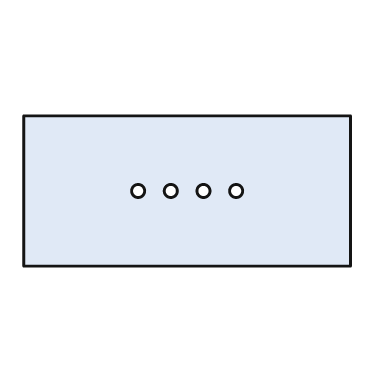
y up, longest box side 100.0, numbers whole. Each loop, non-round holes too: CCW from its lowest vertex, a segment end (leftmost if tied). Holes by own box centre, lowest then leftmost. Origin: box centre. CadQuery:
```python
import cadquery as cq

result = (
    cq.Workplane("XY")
    .moveTo(-50.0, -23.0)
    .lineTo(50.0, -23.0)
    .lineTo(50.0, 23.0)
    .lineTo(-50.0, 23.0)
    .close()
    .moveTo(-15.0, 0.0)
    .circle(2.0)
    .moveTo(-5.0, 0.0)
    .circle(2.0)
    .moveTo(5.0, 0.0)
    .circle(2.0)
    .moveTo(15.0, 0.0)
    .circle(2.0)
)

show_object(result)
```